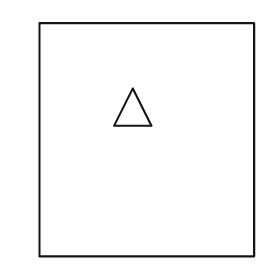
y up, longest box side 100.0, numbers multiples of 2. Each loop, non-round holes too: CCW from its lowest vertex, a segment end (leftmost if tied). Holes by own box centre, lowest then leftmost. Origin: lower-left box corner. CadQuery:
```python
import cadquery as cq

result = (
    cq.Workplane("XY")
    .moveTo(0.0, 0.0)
    .lineTo(92.0, 0.0)
    .lineTo(92.0, 100.0)
    .lineTo(0.0, 100.0)
    .close()
    .moveTo(32.0, 56.0)
    .lineTo(48.0, 56.0)
    .lineTo(40.0, 72.0)
    .close()
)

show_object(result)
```